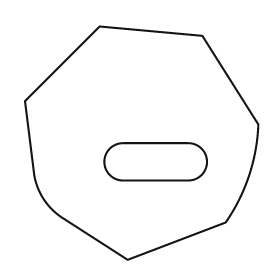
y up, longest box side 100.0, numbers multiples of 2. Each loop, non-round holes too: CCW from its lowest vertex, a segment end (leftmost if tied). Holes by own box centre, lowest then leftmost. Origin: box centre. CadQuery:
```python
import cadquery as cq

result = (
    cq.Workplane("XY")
    .moveTo(-6.0, -50.0)
    .lineTo(36.0, -34.0)
    .threePointArc((46.0, -14.0), (50.0, 8.0))
    .lineTo(26.0, 46.0)
    .lineTo(-18.0, 50.0)
    .lineTo(-50.0, 18.0)
    .lineTo(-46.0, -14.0)
    .threePointArc((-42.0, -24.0), (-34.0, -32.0))
    .close()
    .moveTo(-8.0, -16.0)
    .lineTo(20.0, -16.0)
    .threePointArc((28.0, -8.0), (20.0, 0.0))
    .lineTo(-8.0, 0.0)
    .threePointArc((-16.0, -8.0), (-8.0, -16.0))
    .close()
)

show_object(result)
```